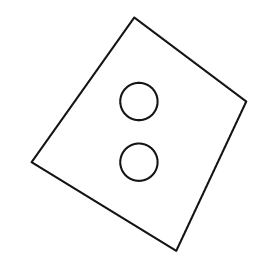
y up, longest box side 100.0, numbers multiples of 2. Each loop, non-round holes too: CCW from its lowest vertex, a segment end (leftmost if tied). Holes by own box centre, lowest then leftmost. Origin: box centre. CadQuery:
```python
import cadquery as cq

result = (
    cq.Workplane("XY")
    .moveTo(16.0, -50.0)
    .lineTo(46.0, 14.0)
    .lineTo(-2.0, 50.0)
    .lineTo(-46.0, -12.0)
    .close()
    .moveTo(0.0, -12.0)
    .circle(8.0)
    .moveTo(0.0, 14.0)
    .circle(8.0)
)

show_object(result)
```